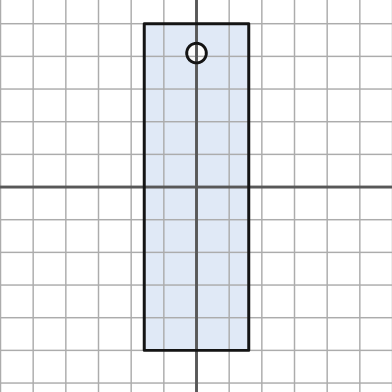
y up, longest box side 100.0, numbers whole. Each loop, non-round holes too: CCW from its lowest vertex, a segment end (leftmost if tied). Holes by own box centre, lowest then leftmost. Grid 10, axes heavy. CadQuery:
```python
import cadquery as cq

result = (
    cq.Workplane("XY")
    .moveTo(-16.0, -50.0)
    .lineTo(16.0, -50.0)
    .lineTo(16.0, 50.0)
    .lineTo(-16.0, 50.0)
    .close()
    .moveTo(0.0, 41.0)
    .circle(3.0)
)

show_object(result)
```